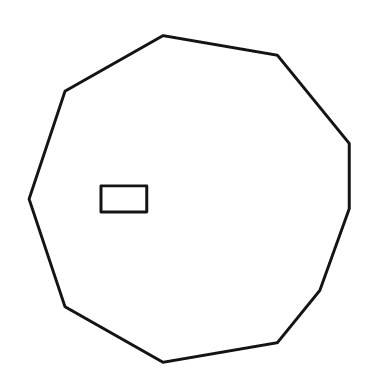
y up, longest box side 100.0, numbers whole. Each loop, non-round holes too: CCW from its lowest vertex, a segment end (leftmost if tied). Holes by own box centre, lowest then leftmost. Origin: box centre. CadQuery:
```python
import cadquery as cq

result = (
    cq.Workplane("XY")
    .moveTo(-8.0, -50.0)
    .lineTo(27.0, -44.0)
    .lineTo(40.0, -28.0)
    .lineTo(49.0, -3.0)
    .lineTo(49.0, 17.0)
    .lineTo(27.0, 44.0)
    .lineTo(-8.0, 50.0)
    .lineTo(-38.0, 33.0)
    .lineTo(-49.0, 0.0)
    .lineTo(-38.0, -33.0)
    .close()
    .moveTo(-27.0, -4.0)
    .lineTo(-13.0, -4.0)
    .lineTo(-13.0, 4.0)
    .lineTo(-27.0, 4.0)
    .close()
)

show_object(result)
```